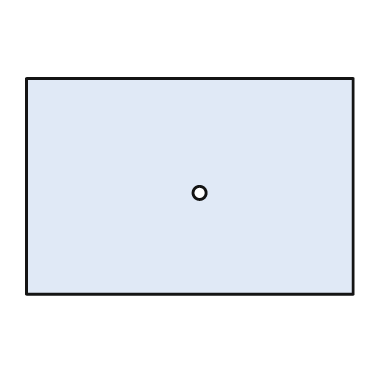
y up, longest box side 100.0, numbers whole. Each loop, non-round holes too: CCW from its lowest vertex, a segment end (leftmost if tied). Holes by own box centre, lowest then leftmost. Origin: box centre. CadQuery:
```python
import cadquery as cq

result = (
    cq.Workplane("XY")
    .moveTo(-50.0, -33.0)
    .lineTo(50.0, -33.0)
    .lineTo(50.0, 33.0)
    .lineTo(-50.0, 33.0)
    .close()
    .moveTo(3.0, -2.0)
    .circle(2.0)
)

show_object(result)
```